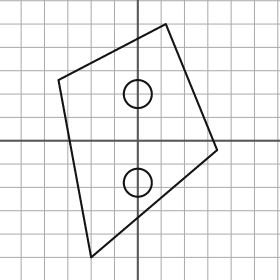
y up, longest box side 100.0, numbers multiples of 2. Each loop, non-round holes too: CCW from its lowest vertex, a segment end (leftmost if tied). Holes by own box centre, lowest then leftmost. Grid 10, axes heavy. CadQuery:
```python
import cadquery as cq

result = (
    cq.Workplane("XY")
    .moveTo(-20.0, -50.0)
    .lineTo(34.0, -4.0)
    .lineTo(12.0, 50.0)
    .lineTo(-34.0, 26.0)
    .close()
    .moveTo(0.0, -18.0)
    .circle(6.0)
    .moveTo(0.0, 20.0)
    .circle(6.0)
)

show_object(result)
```